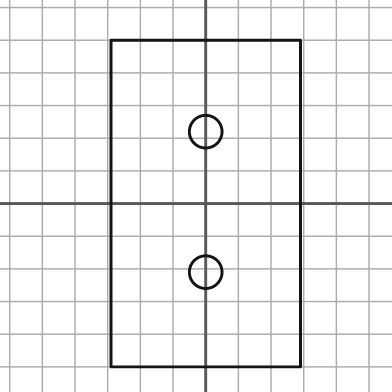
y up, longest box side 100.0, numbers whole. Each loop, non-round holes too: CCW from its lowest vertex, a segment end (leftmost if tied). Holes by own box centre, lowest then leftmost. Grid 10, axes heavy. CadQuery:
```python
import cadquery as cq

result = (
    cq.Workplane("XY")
    .moveTo(-29.0, -50.0)
    .lineTo(29.0, -50.0)
    .lineTo(29.0, 50.0)
    .lineTo(-29.0, 50.0)
    .close()
    .moveTo(0.0, -21.0)
    .circle(5.0)
    .moveTo(0.0, 22.0)
    .circle(5.0)
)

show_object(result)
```